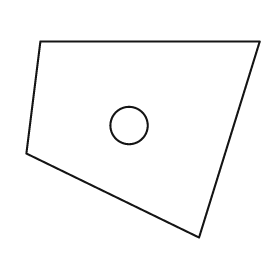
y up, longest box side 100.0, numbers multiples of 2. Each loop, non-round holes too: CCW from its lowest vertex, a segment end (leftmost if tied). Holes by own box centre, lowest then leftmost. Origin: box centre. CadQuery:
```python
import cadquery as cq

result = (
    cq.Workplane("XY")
    .moveTo(24.0, -42.0)
    .lineTo(50.0, 42.0)
    .lineTo(-44.0, 42.0)
    .lineTo(-50.0, -6.0)
    .close()
    .moveTo(-6.0, 6.0)
    .circle(8.0)
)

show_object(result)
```